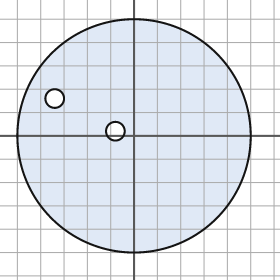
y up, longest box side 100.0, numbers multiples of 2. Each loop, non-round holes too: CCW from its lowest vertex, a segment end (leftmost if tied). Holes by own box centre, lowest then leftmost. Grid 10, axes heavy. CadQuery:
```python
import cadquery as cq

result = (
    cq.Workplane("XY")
    .moveTo(0.0, 0.0)
    .circle(50.0)
    .moveTo(-8.0, 2.0)
    .circle(4.0)
    .moveTo(-34.0, 16.0)
    .circle(4.0)
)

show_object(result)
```